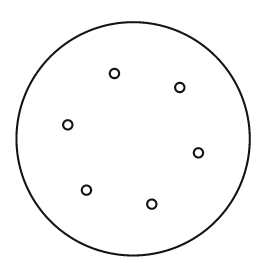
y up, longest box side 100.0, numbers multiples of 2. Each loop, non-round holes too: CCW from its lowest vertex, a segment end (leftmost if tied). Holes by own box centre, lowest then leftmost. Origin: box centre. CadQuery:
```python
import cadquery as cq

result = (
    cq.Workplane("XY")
    .moveTo(0.0, 0.0)
    .circle(50.0)
    .moveTo(8.0, -28.0)
    .circle(2.0)
    .moveTo(-20.0, -22.0)
    .circle(2.0)
    .moveTo(28.0, -6.0)
    .circle(2.0)
    .moveTo(-28.0, 6.0)
    .circle(2.0)
    .moveTo(20.0, 22.0)
    .circle(2.0)
    .moveTo(-8.0, 28.0)
    .circle(2.0)
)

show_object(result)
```